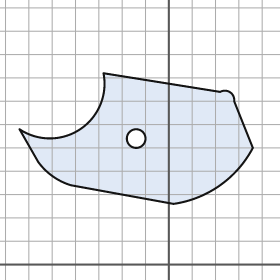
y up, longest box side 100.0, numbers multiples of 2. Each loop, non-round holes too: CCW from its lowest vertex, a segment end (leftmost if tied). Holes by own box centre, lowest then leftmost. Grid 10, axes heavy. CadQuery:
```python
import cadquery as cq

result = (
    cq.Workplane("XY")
    .moveTo(2.0, 26.0)
    .threePointArc((22.0, 34.0), (36.0, 50.0))
    .lineTo(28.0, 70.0)
    .threePointArc((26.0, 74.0), (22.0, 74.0))
    .lineTo(-28.0, 82.0)
    .threePointArc((-38.0, 58.0), (-64.0, 58.0))
    .lineTo(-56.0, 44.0)
    .threePointArc((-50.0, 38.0), (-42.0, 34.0))
    .close()
    .moveTo(-14.0, 54.0)
    .circle(4.0)
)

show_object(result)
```